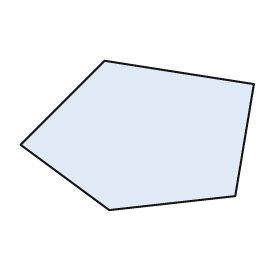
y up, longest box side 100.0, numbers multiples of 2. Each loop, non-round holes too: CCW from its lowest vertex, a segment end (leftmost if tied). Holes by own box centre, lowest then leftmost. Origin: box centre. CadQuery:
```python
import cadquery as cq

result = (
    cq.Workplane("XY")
    .moveTo(-12.0, -32.0)
    .lineTo(42.0, -26.0)
    .lineTo(50.0, 22.0)
    .lineTo(-14.0, 32.0)
    .lineTo(-50.0, -4.0)
    .close()
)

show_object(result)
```